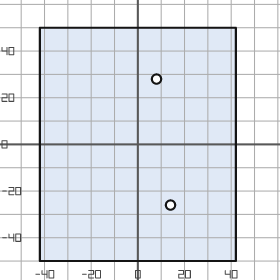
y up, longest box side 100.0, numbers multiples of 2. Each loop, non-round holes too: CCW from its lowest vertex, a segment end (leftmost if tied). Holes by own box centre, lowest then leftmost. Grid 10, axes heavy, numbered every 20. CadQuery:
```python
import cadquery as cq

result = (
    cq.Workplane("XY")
    .moveTo(-42.0, -50.0)
    .lineTo(42.0, -50.0)
    .lineTo(42.0, 50.0)
    .lineTo(-42.0, 50.0)
    .close()
    .moveTo(14.0, -26.0)
    .circle(2.0)
    .moveTo(8.0, 28.0)
    .circle(2.0)
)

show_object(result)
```